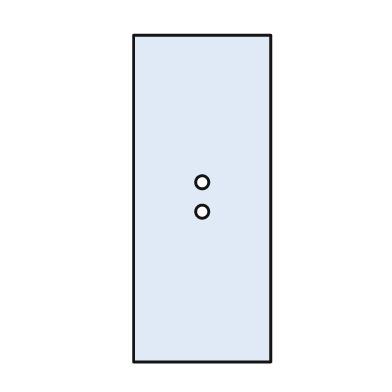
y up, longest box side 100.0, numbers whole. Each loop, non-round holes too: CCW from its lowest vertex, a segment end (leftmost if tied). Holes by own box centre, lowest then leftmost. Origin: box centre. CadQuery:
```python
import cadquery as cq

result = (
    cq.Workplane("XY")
    .moveTo(-21.0, -50.0)
    .lineTo(21.0, -50.0)
    .lineTo(21.0, 50.0)
    .lineTo(-21.0, 50.0)
    .close()
    .moveTo(0.0, -4.0)
    .circle(2.0)
    .moveTo(0.0, 5.0)
    .circle(2.0)
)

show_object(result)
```